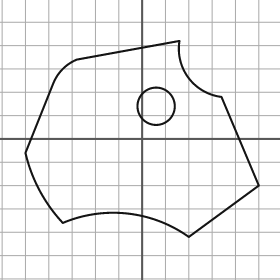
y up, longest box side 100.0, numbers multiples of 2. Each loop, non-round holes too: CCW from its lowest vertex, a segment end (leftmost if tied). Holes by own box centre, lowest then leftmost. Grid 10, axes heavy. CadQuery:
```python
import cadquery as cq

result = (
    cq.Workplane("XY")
    .moveTo(20.0, -42.0)
    .lineTo(50.0, -20.0)
    .lineTo(34.0, 18.0)
    .threePointArc((20.0, 26.0), (16.0, 42.0))
    .lineTo(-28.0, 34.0)
    .threePointArc((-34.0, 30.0), (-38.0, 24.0))
    .lineTo(-50.0, -6.0)
    .threePointArc((-44.0, -22.0), (-34.0, -36.0))
    .threePointArc((-6.0, -32.0), (20.0, -42.0))
    .close()
    .moveTo(6.0, 14.0)
    .circle(8.0)
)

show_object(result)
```